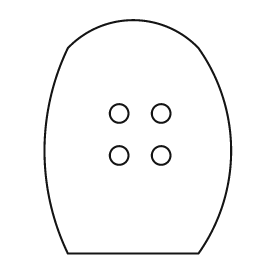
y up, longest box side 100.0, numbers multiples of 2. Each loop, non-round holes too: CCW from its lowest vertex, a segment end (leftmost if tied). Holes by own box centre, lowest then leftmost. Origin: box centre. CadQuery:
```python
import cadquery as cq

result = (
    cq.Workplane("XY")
    .moveTo(-30.0, -50.0)
    .lineTo(26.0, -50.0)
    .threePointArc((40.0, -6.0), (26.0, 38.0))
    .threePointArc((-2.0, 50.0), (-30.0, 38.0))
    .threePointArc((-40.0, -6.0), (-30.0, -50.0))
    .close()
    .moveTo(-8.0, -8.0)
    .circle(4.0)
    .moveTo(10.0, -8.0)
    .circle(4.0)
    .moveTo(-8.0, 10.0)
    .circle(4.0)
    .moveTo(10.0, 10.0)
    .circle(4.0)
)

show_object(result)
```